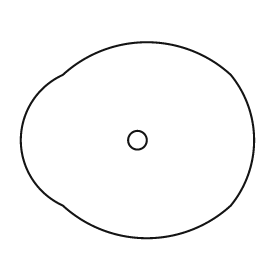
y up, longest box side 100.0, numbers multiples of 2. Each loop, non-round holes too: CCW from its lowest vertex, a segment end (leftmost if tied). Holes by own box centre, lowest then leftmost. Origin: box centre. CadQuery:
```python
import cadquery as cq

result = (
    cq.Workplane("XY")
    .moveTo(-32.0, -28.0)
    .threePointArc((4.0, -42.0), (40.0, -28.0))
    .threePointArc((50.0, 0.0), (40.0, 28.0))
    .threePointArc((4.0, 42.0), (-32.0, 28.0))
    .threePointArc((-50.0, 0.0), (-32.0, -28.0))
    .close()
    .moveTo(0.0, 0.0)
    .circle(4.0)
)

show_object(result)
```